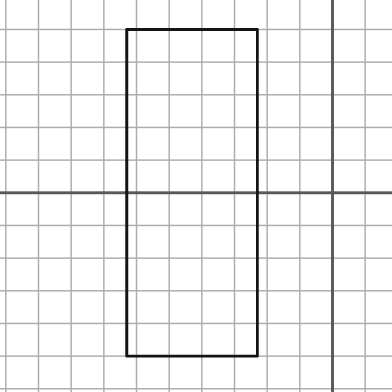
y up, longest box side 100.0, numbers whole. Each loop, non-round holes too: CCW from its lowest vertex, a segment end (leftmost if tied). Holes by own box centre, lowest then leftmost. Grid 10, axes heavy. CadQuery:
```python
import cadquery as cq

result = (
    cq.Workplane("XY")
    .moveTo(-63.0, -50.0)
    .lineTo(-23.0, -50.0)
    .lineTo(-23.0, 50.0)
    .lineTo(-63.0, 50.0)
    .close()
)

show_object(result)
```